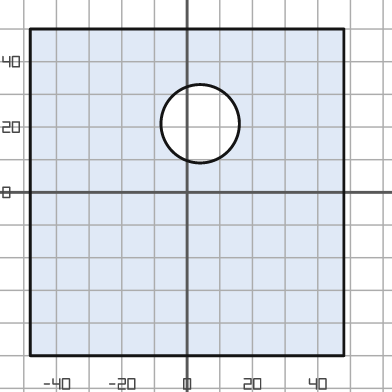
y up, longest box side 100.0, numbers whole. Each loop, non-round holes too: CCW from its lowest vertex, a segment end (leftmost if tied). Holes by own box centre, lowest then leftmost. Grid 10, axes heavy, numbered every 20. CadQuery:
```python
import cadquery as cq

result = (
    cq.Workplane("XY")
    .moveTo(-48.0, -50.0)
    .lineTo(48.0, -50.0)
    .lineTo(48.0, 50.0)
    .lineTo(-48.0, 50.0)
    .close()
    .moveTo(4.0, 21.0)
    .circle(12.0)
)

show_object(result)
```